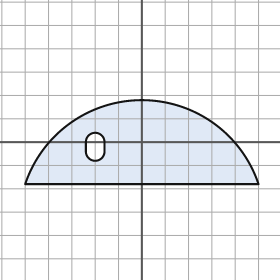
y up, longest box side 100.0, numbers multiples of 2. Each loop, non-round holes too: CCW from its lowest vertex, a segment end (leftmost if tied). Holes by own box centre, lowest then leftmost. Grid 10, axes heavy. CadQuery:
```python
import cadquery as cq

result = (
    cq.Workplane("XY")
    .moveTo(-50.0, -18.0)
    .lineTo(50.0, -18.0)
    .threePointArc((0.0, 18.0), (-50.0, -18.0))
    .close()
    .moveTo(-24.0, -4.0)
    .threePointArc((-20.0, -8.0), (-16.0, -4.0))
    .lineTo(-16.0, 0.0)
    .threePointArc((-20.0, 4.0), (-24.0, 0.0))
    .close()
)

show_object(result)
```